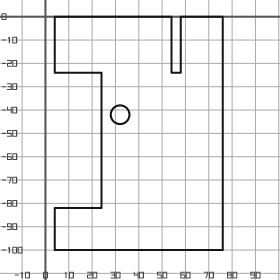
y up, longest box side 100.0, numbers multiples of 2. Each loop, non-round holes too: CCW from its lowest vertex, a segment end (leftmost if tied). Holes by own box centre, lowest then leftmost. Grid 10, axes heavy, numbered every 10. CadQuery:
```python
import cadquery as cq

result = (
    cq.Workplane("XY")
    .moveTo(4.0, -100.0)
    .lineTo(76.0, -100.0)
    .lineTo(76.0, 0.0)
    .lineTo(58.0, 0.0)
    .lineTo(58.0, -24.0)
    .lineTo(54.0, -24.0)
    .lineTo(54.0, 0.0)
    .lineTo(4.0, 0.0)
    .lineTo(4.0, -24.0)
    .lineTo(24.0, -24.0)
    .lineTo(24.0, -82.0)
    .lineTo(4.0, -82.0)
    .close()
    .moveTo(32.0, -42.0)
    .circle(4.0)
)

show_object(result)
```